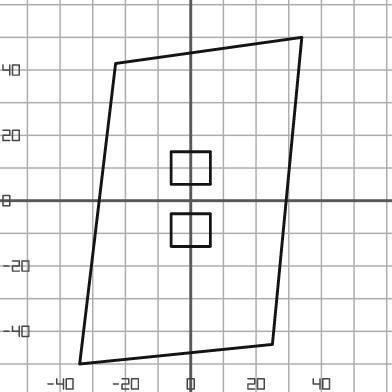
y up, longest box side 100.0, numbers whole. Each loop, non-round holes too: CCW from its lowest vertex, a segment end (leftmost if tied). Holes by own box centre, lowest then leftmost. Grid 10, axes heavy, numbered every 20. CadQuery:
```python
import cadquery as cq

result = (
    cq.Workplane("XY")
    .moveTo(-34.0, -50.0)
    .lineTo(25.0, -44.0)
    .lineTo(34.0, 50.0)
    .lineTo(-23.0, 42.0)
    .close()
    .moveTo(-6.0, -14.0)
    .lineTo(6.0, -14.0)
    .lineTo(6.0, -4.0)
    .lineTo(-6.0, -4.0)
    .close()
    .moveTo(-6.0, 5.0)
    .lineTo(6.0, 5.0)
    .lineTo(6.0, 15.0)
    .lineTo(-6.0, 15.0)
    .close()
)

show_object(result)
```